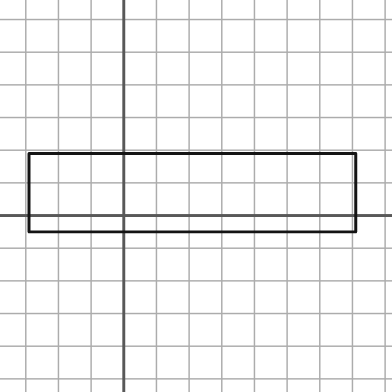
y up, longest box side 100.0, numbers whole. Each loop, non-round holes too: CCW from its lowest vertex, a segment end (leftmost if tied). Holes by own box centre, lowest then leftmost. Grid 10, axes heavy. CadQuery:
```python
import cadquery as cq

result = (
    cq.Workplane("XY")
    .moveTo(-29.0, -5.0)
    .lineTo(71.0, -5.0)
    .lineTo(71.0, 19.0)
    .lineTo(-29.0, 19.0)
    .close()
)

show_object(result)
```